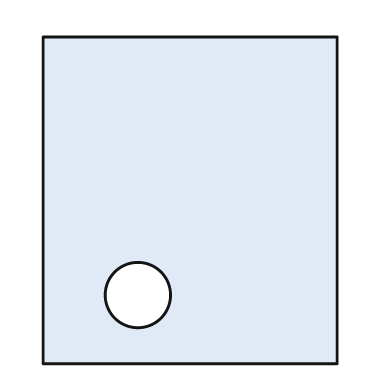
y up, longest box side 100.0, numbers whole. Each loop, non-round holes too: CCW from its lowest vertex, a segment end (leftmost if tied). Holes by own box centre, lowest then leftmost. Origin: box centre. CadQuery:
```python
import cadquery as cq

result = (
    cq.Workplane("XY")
    .moveTo(-45.0, -50.0)
    .lineTo(45.0, -50.0)
    .lineTo(45.0, 50.0)
    .lineTo(-45.0, 50.0)
    .close()
    .moveTo(-16.0, -29.0)
    .circle(10.0)
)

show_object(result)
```